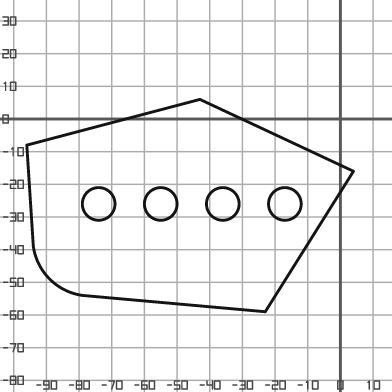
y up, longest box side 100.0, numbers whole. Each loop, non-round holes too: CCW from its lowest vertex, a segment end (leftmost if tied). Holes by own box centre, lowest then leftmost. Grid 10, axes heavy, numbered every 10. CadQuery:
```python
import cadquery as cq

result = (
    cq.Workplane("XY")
    .moveTo(-23.0, -59.0)
    .lineTo(4.0, -16.0)
    .lineTo(-43.0, 6.0)
    .lineTo(-96.0, -8.0)
    .lineTo(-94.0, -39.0)
    .threePointArc((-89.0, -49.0), (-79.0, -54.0))
    .close()
    .moveTo(-74.0, -26.0)
    .circle(5.0)
    .moveTo(-55.0, -26.0)
    .circle(5.0)
    .moveTo(-36.0, -26.0)
    .circle(5.0)
    .moveTo(-17.0, -26.0)
    .circle(5.0)
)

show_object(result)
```